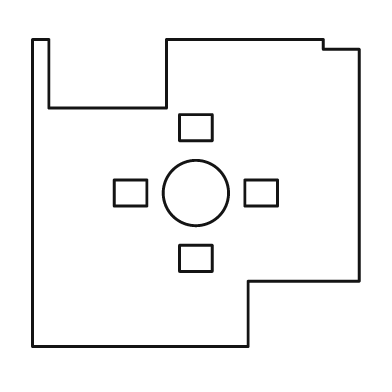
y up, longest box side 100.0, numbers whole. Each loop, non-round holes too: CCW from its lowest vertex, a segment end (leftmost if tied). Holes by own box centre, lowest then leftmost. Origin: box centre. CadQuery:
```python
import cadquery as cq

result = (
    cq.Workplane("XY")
    .moveTo(-50.0, -47.0)
    .lineTo(16.0, -47.0)
    .lineTo(16.0, -27.0)
    .lineTo(50.0, -27.0)
    .lineTo(50.0, 44.0)
    .lineTo(39.0, 44.0)
    .lineTo(39.0, 47.0)
    .lineTo(-9.0, 47.0)
    .lineTo(-9.0, 26.0)
    .lineTo(-45.0, 26.0)
    .lineTo(-45.0, 47.0)
    .lineTo(-50.0, 47.0)
    .close()
    .moveTo(-5.0, -24.0)
    .lineTo(5.0, -24.0)
    .lineTo(5.0, -16.0)
    .lineTo(-5.0, -16.0)
    .close()
    .moveTo(-25.0, -4.0)
    .lineTo(-15.0, -4.0)
    .lineTo(-15.0, 4.0)
    .lineTo(-25.0, 4.0)
    .close()
    .moveTo(0.0, 0.0)
    .circle(10.0)
    .moveTo(15.0, -4.0)
    .lineTo(25.0, -4.0)
    .lineTo(25.0, 4.0)
    .lineTo(15.0, 4.0)
    .close()
    .moveTo(-5.0, 16.0)
    .lineTo(5.0, 16.0)
    .lineTo(5.0, 24.0)
    .lineTo(-5.0, 24.0)
    .close()
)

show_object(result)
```